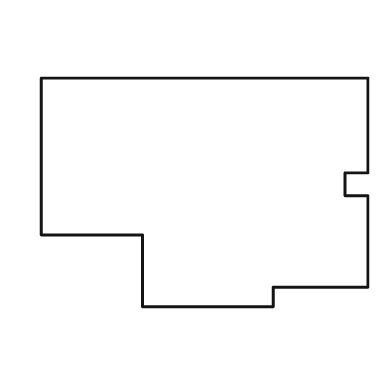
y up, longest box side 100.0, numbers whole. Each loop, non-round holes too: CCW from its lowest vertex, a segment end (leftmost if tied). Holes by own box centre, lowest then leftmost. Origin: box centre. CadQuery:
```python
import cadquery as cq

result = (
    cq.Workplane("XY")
    .moveTo(-19.0, -35.0)
    .lineTo(21.0, -35.0)
    .lineTo(21.0, -29.0)
    .lineTo(50.0, -29.0)
    .lineTo(50.0, -1.0)
    .lineTo(43.0, -1.0)
    .lineTo(43.0, 6.0)
    .lineTo(50.0, 6.0)
    .lineTo(50.0, 35.0)
    .lineTo(-50.0, 35.0)
    .lineTo(-50.0, -13.0)
    .lineTo(-19.0, -13.0)
    .close()
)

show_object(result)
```